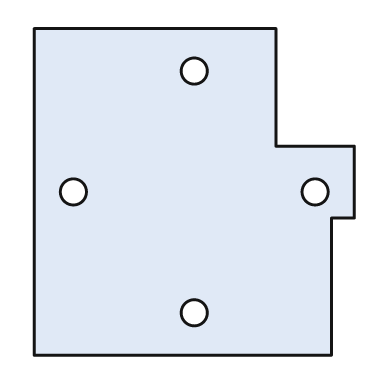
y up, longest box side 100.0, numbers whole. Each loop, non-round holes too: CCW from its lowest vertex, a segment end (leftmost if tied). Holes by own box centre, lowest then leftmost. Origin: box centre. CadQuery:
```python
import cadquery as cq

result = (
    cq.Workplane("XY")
    .moveTo(-49.0, -50.0)
    .lineTo(42.0, -50.0)
    .lineTo(42.0, -8.0)
    .lineTo(49.0, -8.0)
    .lineTo(49.0, 14.0)
    .lineTo(25.0, 14.0)
    .lineTo(25.0, 50.0)
    .lineTo(-49.0, 50.0)
    .close()
    .moveTo(0.0, -37.0)
    .circle(4.0)
    .moveTo(-37.0, 0.0)
    .circle(4.0)
    .moveTo(37.0, 0.0)
    .circle(4.0)
    .moveTo(0.0, 37.0)
    .circle(4.0)
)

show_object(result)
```